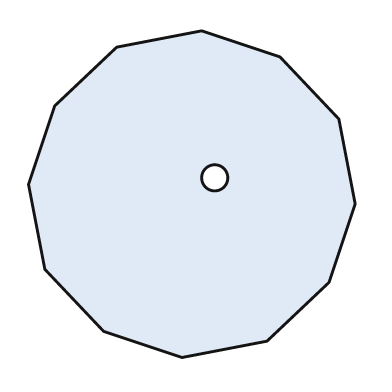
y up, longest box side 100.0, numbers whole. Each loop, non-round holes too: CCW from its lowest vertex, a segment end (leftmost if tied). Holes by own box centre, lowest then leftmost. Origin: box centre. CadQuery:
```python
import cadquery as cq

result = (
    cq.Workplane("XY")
    .moveTo(-3.0, -50.0)
    .lineTo(23.0, -45.0)
    .lineTo(42.0, -27.0)
    .lineTo(50.0, -3.0)
    .lineTo(45.0, 23.0)
    .lineTo(27.0, 42.0)
    .lineTo(3.0, 50.0)
    .lineTo(-23.0, 45.0)
    .lineTo(-42.0, 27.0)
    .lineTo(-50.0, 3.0)
    .lineTo(-45.0, -23.0)
    .lineTo(-27.0, -42.0)
    .close()
    .moveTo(7.0, 5.0)
    .circle(4.0)
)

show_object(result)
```